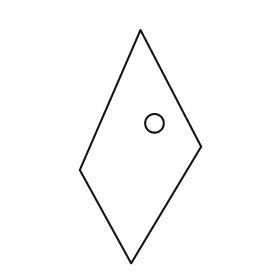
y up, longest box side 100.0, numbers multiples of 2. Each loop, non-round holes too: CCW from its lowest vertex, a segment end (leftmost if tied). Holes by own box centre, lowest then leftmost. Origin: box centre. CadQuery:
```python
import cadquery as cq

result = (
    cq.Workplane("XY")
    .moveTo(-4.0, -50.0)
    .lineTo(26.0, 0.0)
    .lineTo(0.0, 50.0)
    .lineTo(-26.0, -10.0)
    .close()
    .moveTo(6.0, 10.0)
    .circle(4.0)
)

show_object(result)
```